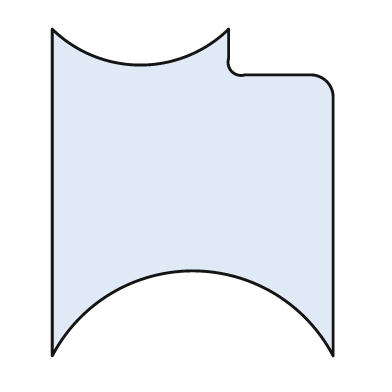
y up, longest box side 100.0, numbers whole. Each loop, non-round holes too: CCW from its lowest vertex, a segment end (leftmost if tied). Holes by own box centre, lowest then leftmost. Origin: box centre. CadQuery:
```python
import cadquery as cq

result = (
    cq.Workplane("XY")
    .moveTo(-43.0, -50.0)
    .threePointArc((0.0, -24.0), (43.0, -50.0))
    .lineTo(43.0, 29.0)
    .threePointArc((41.0, 34.0), (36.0, 36.0))
    .lineTo(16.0, 36.0)
    .threePointArc((12.0, 37.0), (11.0, 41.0))
    .lineTo(11.0, 50.0)
    .threePointArc((-16.0, 39.0), (-43.0, 50.0))
    .close()
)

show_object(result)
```